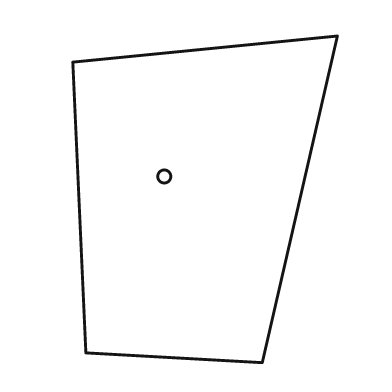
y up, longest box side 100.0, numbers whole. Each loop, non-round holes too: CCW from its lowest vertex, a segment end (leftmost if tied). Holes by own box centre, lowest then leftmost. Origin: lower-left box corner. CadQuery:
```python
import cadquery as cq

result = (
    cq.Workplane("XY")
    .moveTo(58.0, 0.0)
    .lineTo(81.0, 100.0)
    .lineTo(0.0, 92.0)
    .lineTo(4.0, 3.0)
    .close()
    .moveTo(28.0, 57.0)
    .circle(2.0)
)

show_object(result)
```